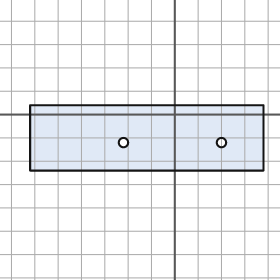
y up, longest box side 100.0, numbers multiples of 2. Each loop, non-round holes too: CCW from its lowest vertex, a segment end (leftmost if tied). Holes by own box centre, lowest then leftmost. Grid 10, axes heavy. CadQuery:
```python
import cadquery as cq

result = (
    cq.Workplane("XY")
    .moveTo(-62.0, -24.0)
    .lineTo(38.0, -24.0)
    .lineTo(38.0, 4.0)
    .lineTo(-62.0, 4.0)
    .close()
    .moveTo(-22.0, -12.0)
    .circle(2.0)
    .moveTo(20.0, -12.0)
    .circle(2.0)
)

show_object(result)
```